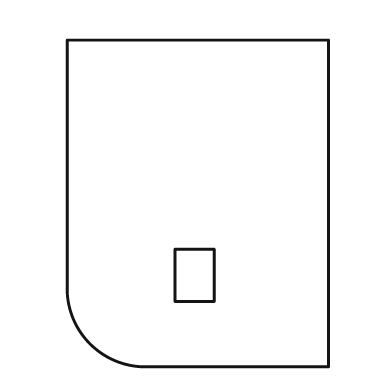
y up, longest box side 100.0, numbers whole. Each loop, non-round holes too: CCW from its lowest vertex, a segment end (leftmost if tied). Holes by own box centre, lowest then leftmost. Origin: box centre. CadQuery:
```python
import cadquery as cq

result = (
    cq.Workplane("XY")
    .moveTo(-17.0, -50.0)
    .lineTo(40.0, -50.0)
    .lineTo(40.0, 50.0)
    .lineTo(-40.0, 50.0)
    .lineTo(-40.0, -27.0)
    .threePointArc((-33.0, -43.0), (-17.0, -50.0))
    .close()
    .moveTo(-7.0, -30.0)
    .lineTo(5.0, -30.0)
    .lineTo(5.0, -14.0)
    .lineTo(-7.0, -14.0)
    .close()
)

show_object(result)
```